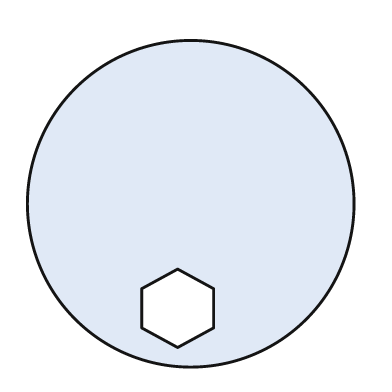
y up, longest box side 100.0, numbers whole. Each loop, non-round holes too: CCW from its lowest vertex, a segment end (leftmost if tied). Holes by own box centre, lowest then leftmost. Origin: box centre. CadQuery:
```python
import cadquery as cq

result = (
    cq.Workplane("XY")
    .moveTo(0.0, 0.0)
    .circle(50.0)
    .moveTo(-4.0, -44.0)
    .lineTo(7.0, -38.0)
    .lineTo(7.0, -26.0)
    .lineTo(-4.0, -20.0)
    .lineTo(-15.0, -26.0)
    .lineTo(-15.0, -38.0)
    .close()
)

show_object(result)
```